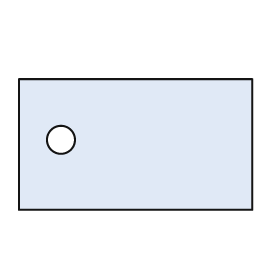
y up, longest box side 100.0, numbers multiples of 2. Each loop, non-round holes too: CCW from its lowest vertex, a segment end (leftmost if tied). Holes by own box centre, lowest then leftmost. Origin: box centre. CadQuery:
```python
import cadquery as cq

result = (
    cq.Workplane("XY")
    .moveTo(-50.0, -28.0)
    .lineTo(50.0, -28.0)
    .lineTo(50.0, 28.0)
    .lineTo(-50.0, 28.0)
    .close()
    .moveTo(-32.0, 2.0)
    .circle(6.0)
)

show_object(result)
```